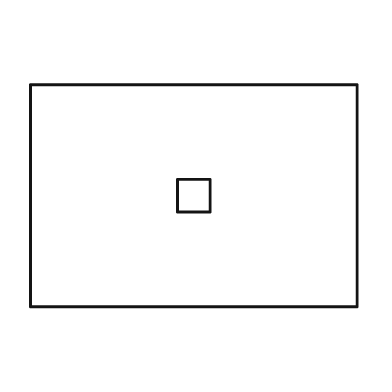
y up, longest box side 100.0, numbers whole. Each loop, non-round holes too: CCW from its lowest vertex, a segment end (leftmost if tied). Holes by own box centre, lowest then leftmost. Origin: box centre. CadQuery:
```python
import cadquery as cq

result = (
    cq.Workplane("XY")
    .moveTo(-50.0, -34.0)
    .lineTo(50.0, -34.0)
    .lineTo(50.0, 34.0)
    .lineTo(-50.0, 34.0)
    .close()
    .moveTo(-5.0, -5.0)
    .lineTo(5.0, -5.0)
    .lineTo(5.0, 5.0)
    .lineTo(-5.0, 5.0)
    .close()
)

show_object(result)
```